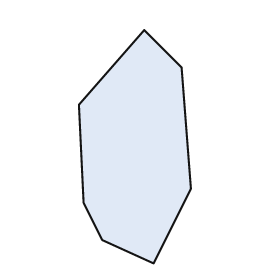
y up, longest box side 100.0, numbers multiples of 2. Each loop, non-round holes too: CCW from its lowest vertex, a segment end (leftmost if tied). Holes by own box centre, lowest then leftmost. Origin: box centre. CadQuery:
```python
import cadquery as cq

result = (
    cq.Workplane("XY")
    .moveTo(8.0, -50.0)
    .lineTo(24.0, -18.0)
    .lineTo(20.0, 34.0)
    .lineTo(4.0, 50.0)
    .lineTo(-24.0, 18.0)
    .lineTo(-22.0, -24.0)
    .lineTo(-14.0, -40.0)
    .close()
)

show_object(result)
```